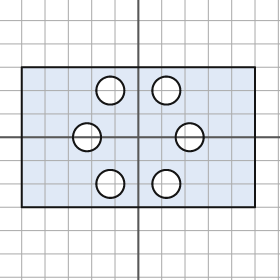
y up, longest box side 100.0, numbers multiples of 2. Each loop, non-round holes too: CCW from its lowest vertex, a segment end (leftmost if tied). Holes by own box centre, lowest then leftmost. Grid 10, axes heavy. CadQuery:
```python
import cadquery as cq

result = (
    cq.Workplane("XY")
    .moveTo(-50.0, -30.0)
    .lineTo(50.0, -30.0)
    .lineTo(50.0, 30.0)
    .lineTo(-50.0, 30.0)
    .close()
    .moveTo(-12.0, -20.0)
    .circle(6.0)
    .moveTo(12.0, -20.0)
    .circle(6.0)
    .moveTo(-22.0, 0.0)
    .circle(6.0)
    .moveTo(22.0, 0.0)
    .circle(6.0)
    .moveTo(-12.0, 20.0)
    .circle(6.0)
    .moveTo(12.0, 20.0)
    .circle(6.0)
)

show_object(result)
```